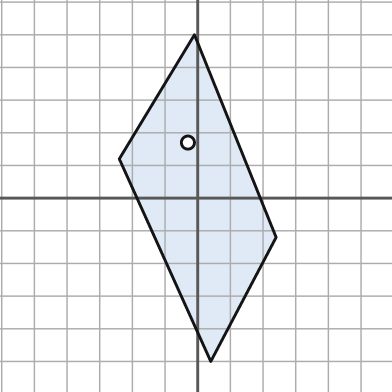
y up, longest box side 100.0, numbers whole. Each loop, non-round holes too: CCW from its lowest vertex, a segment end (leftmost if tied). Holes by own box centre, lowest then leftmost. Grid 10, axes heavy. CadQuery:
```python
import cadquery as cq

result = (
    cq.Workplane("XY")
    .moveTo(4.0, -50.0)
    .lineTo(24.0, -12.0)
    .lineTo(-1.0, 50.0)
    .lineTo(-24.0, 12.0)
    .close()
    .moveTo(-3.0, 17.0)
    .circle(2.0)
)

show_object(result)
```